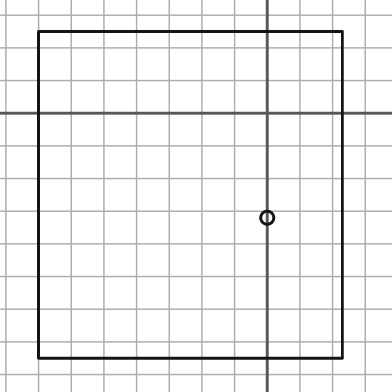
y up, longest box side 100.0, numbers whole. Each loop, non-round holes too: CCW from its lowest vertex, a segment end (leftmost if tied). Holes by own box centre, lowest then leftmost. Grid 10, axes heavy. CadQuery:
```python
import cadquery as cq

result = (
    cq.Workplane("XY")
    .moveTo(-70.0, -75.0)
    .lineTo(23.0, -75.0)
    .lineTo(23.0, 25.0)
    .lineTo(-70.0, 25.0)
    .close()
    .moveTo(0.0, -32.0)
    .circle(2.0)
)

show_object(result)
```